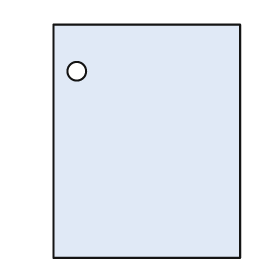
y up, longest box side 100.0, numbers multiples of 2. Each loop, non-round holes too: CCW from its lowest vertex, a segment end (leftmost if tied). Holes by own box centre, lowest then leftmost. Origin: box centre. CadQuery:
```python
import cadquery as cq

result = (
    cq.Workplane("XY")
    .moveTo(-40.0, -50.0)
    .lineTo(40.0, -50.0)
    .lineTo(40.0, 50.0)
    .lineTo(-40.0, 50.0)
    .close()
    .moveTo(-30.0, 30.0)
    .circle(4.0)
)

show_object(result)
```